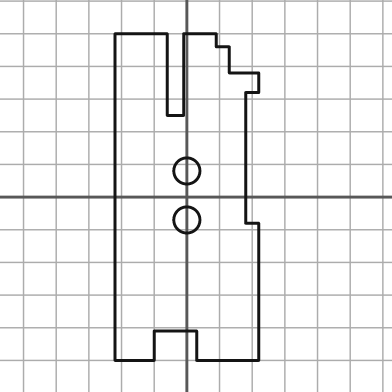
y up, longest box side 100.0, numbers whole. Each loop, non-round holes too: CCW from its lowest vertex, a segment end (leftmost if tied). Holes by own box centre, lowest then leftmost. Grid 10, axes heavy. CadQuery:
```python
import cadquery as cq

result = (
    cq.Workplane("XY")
    .moveTo(-22.0, -50.0)
    .lineTo(-10.0, -50.0)
    .lineTo(-10.0, -41.0)
    .lineTo(3.0, -41.0)
    .lineTo(3.0, -50.0)
    .lineTo(22.0, -50.0)
    .lineTo(22.0, -8.0)
    .lineTo(18.0, -8.0)
    .lineTo(18.0, 32.0)
    .lineTo(22.0, 32.0)
    .lineTo(22.0, 38.0)
    .lineTo(13.0, 38.0)
    .lineTo(13.0, 46.0)
    .lineTo(9.0, 46.0)
    .lineTo(9.0, 50.0)
    .lineTo(-1.0, 50.0)
    .lineTo(-1.0, 25.0)
    .lineTo(-6.0, 25.0)
    .lineTo(-6.0, 50.0)
    .lineTo(-22.0, 50.0)
    .close()
    .moveTo(0.0, -7.0)
    .circle(4.0)
    .moveTo(0.0, 8.0)
    .circle(4.0)
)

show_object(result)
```